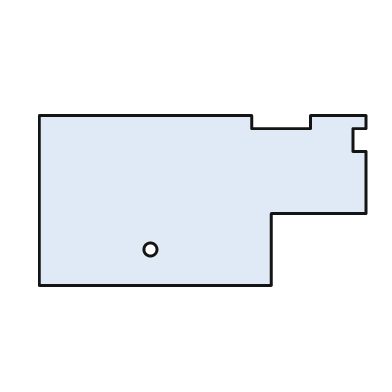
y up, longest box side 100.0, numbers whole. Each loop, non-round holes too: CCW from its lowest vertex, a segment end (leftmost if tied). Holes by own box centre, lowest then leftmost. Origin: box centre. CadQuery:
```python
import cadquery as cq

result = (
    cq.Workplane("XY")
    .moveTo(-50.0, -26.0)
    .lineTo(21.0, -26.0)
    .lineTo(21.0, -4.0)
    .lineTo(50.0, -4.0)
    .lineTo(50.0, 15.0)
    .lineTo(46.0, 15.0)
    .lineTo(46.0, 22.0)
    .lineTo(50.0, 22.0)
    .lineTo(50.0, 26.0)
    .lineTo(33.0, 26.0)
    .lineTo(33.0, 22.0)
    .lineTo(15.0, 22.0)
    .lineTo(15.0, 26.0)
    .lineTo(-50.0, 26.0)
    .close()
    .moveTo(-16.0, -15.0)
    .circle(2.0)
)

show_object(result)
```